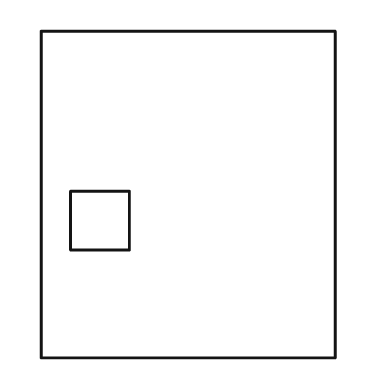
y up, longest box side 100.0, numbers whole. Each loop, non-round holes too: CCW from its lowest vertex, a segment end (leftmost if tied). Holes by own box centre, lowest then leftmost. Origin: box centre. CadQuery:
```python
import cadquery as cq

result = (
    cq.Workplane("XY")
    .moveTo(-45.0, -50.0)
    .lineTo(45.0, -50.0)
    .lineTo(45.0, 50.0)
    .lineTo(-45.0, 50.0)
    .close()
    .moveTo(-36.0, -17.0)
    .lineTo(-18.0, -17.0)
    .lineTo(-18.0, 1.0)
    .lineTo(-36.0, 1.0)
    .close()
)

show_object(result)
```